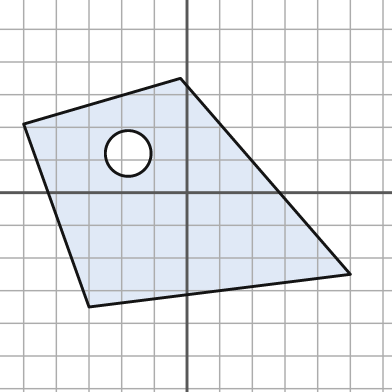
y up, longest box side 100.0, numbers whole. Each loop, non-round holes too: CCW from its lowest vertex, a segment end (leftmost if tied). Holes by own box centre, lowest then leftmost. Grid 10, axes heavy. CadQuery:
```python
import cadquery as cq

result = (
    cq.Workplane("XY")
    .moveTo(-30.0, -35.0)
    .lineTo(50.0, -25.0)
    .lineTo(-2.0, 35.0)
    .lineTo(-50.0, 21.0)
    .close()
    .moveTo(-18.0, 12.0)
    .circle(7.0)
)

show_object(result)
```